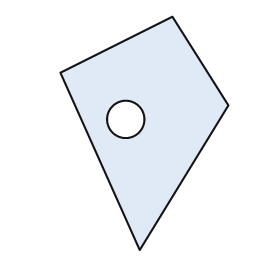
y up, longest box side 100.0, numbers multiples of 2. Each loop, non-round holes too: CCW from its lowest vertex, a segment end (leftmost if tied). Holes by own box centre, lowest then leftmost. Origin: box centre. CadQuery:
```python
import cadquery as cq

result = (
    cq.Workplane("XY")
    .moveTo(-2.0, -50.0)
    .lineTo(36.0, 12.0)
    .lineTo(12.0, 50.0)
    .lineTo(-36.0, 26.0)
    .close()
    .moveTo(-8.0, 6.0)
    .circle(8.0)
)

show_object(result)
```